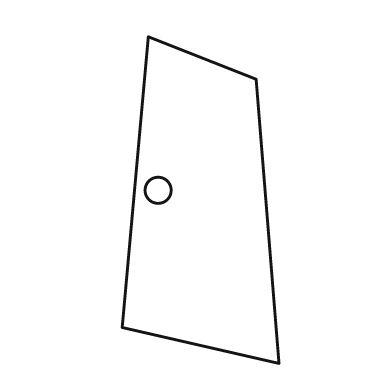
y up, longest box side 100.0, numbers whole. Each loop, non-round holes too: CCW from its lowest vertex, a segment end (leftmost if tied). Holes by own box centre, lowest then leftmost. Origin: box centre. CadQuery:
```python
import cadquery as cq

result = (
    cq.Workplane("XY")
    .moveTo(24.0, -50.0)
    .lineTo(17.0, 37.0)
    .lineTo(-16.0, 50.0)
    .lineTo(-24.0, -39.0)
    .close()
    .moveTo(-13.0, 3.0)
    .circle(4.0)
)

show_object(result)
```